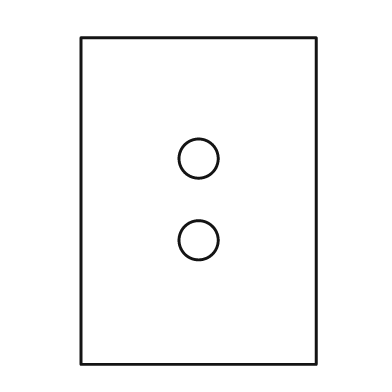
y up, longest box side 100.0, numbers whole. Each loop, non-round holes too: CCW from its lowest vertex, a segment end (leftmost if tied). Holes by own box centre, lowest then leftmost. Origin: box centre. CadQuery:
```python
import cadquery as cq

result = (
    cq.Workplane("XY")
    .moveTo(-36.0, -50.0)
    .lineTo(36.0, -50.0)
    .lineTo(36.0, 50.0)
    .lineTo(-36.0, 50.0)
    .close()
    .moveTo(0.0, -12.0)
    .circle(6.0)
    .moveTo(0.0, 13.0)
    .circle(6.0)
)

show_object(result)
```